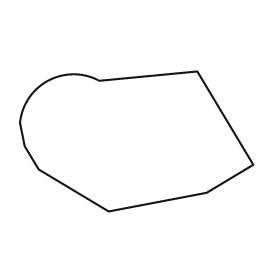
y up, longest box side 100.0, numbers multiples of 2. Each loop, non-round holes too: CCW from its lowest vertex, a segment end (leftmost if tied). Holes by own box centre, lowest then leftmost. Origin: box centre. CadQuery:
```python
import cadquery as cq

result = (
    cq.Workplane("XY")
    .moveTo(-12.0, -30.0)
    .lineTo(30.0, -22.0)
    .lineTo(50.0, -10.0)
    .lineTo(26.0, 30.0)
    .lineTo(-16.0, 26.0)
    .threePointArc((-38.0, 26.0), (-50.0, 8.0))
    .lineTo(-48.0, -2.0)
    .lineTo(-42.0, -12.0)
    .close()
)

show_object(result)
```